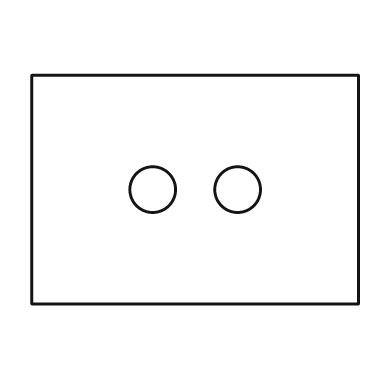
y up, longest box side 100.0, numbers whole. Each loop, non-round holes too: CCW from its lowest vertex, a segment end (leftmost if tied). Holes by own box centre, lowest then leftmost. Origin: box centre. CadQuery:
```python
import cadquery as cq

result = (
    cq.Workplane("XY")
    .moveTo(-50.0, -35.0)
    .lineTo(50.0, -35.0)
    .lineTo(50.0, 35.0)
    .lineTo(-50.0, 35.0)
    .close()
    .moveTo(-13.0, 0.0)
    .circle(7.0)
    .moveTo(13.0, 0.0)
    .circle(7.0)
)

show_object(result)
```